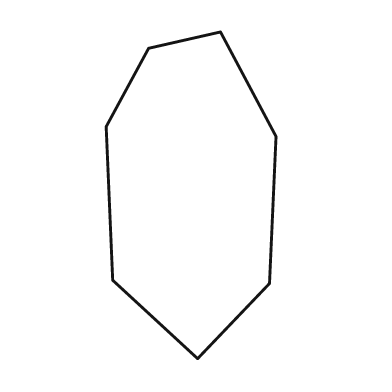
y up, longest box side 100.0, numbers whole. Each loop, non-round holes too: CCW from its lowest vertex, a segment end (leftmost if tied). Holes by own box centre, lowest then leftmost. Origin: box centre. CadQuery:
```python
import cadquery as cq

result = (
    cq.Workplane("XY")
    .moveTo(2.0, -50.0)
    .lineTo(24.0, -27.0)
    .lineTo(26.0, 18.0)
    .lineTo(9.0, 50.0)
    .lineTo(-13.0, 45.0)
    .lineTo(-26.0, 21.0)
    .lineTo(-24.0, -26.0)
    .close()
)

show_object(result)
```